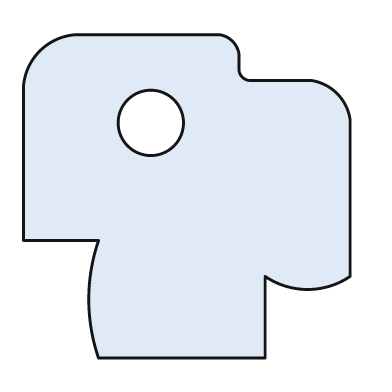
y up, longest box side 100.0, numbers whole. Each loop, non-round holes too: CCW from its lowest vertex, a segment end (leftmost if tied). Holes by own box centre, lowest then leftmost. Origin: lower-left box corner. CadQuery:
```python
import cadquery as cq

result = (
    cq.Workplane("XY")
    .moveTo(23.0, 0.0)
    .lineTo(74.0, 0.0)
    .lineTo(74.0, 25.0)
    .threePointArc((87.0, 21.0), (100.0, 25.0))
    .lineTo(100.0, 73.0)
    .threePointArc((96.0, 81.0), (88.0, 85.0))
    .lineTo(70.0, 85.0)
    .threePointArc((67.0, 86.0), (66.0, 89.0))
    .lineTo(66.0, 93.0)
    .threePointArc((64.0, 97.0), (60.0, 99.0))
    .lineTo(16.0, 99.0)
    .threePointArc((5.0, 94.0), (0.0, 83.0))
    .lineTo(0.0, 36.0)
    .lineTo(23.0, 36.0)
    .threePointArc((20.0, 18.0), (23.0, 0.0))
    .close()
    .moveTo(39.0, 72.0)
    .circle(10.0)
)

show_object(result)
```